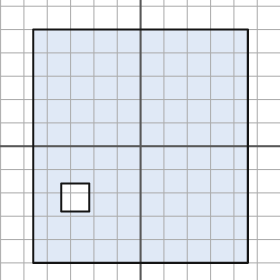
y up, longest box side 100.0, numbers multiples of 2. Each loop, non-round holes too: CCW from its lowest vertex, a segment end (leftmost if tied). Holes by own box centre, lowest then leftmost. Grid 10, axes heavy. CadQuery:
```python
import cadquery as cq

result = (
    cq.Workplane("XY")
    .moveTo(-46.0, -50.0)
    .lineTo(46.0, -50.0)
    .lineTo(46.0, 50.0)
    .lineTo(-46.0, 50.0)
    .close()
    .moveTo(-34.0, -28.0)
    .lineTo(-22.0, -28.0)
    .lineTo(-22.0, -16.0)
    .lineTo(-34.0, -16.0)
    .close()
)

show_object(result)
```